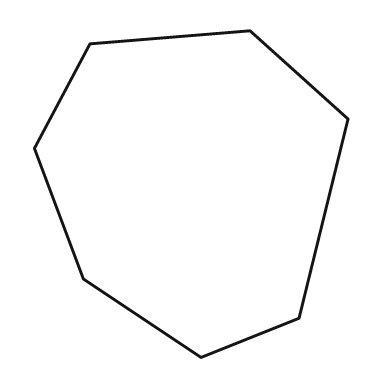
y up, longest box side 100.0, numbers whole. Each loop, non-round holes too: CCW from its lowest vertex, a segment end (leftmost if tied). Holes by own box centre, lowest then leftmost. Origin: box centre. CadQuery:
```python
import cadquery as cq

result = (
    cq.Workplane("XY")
    .moveTo(3.0, -50.0)
    .lineTo(33.0, -38.0)
    .lineTo(48.0, 23.0)
    .lineTo(18.0, 50.0)
    .lineTo(-31.0, 46.0)
    .lineTo(-48.0, 14.0)
    .lineTo(-33.0, -26.0)
    .close()
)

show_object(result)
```